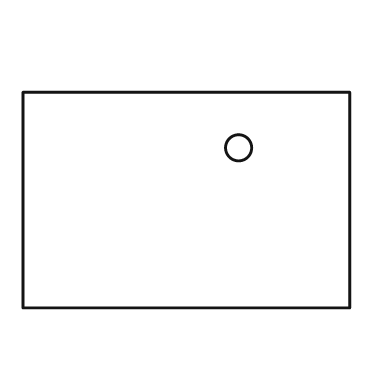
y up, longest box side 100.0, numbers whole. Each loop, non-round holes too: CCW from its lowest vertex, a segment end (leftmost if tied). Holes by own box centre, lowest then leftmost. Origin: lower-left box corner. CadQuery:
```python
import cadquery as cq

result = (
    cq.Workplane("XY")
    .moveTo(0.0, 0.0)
    .lineTo(100.0, 0.0)
    .lineTo(100.0, 66.0)
    .lineTo(0.0, 66.0)
    .close()
    .moveTo(66.0, 49.0)
    .circle(4.0)
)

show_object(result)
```